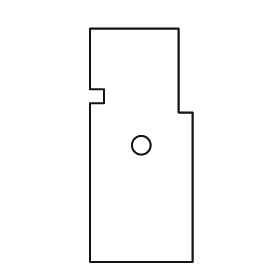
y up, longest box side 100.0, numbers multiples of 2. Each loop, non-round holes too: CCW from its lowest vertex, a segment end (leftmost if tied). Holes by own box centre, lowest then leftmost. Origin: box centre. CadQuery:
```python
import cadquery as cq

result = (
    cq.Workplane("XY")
    .moveTo(-22.0, -50.0)
    .lineTo(22.0, -50.0)
    .lineTo(22.0, 14.0)
    .lineTo(16.0, 14.0)
    .lineTo(16.0, 50.0)
    .lineTo(-22.0, 50.0)
    .lineTo(-22.0, 24.0)
    .lineTo(-16.0, 24.0)
    .lineTo(-16.0, 18.0)
    .lineTo(-22.0, 18.0)
    .close()
    .moveTo(0.0, 0.0)
    .circle(4.0)
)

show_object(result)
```